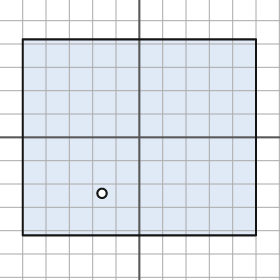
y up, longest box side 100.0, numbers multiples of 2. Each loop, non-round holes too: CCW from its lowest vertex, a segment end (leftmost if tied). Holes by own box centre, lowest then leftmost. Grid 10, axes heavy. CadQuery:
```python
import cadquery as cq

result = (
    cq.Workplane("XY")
    .moveTo(-50.0, -42.0)
    .lineTo(50.0, -42.0)
    .lineTo(50.0, 42.0)
    .lineTo(-50.0, 42.0)
    .close()
    .moveTo(-16.0, -24.0)
    .circle(2.0)
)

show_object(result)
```